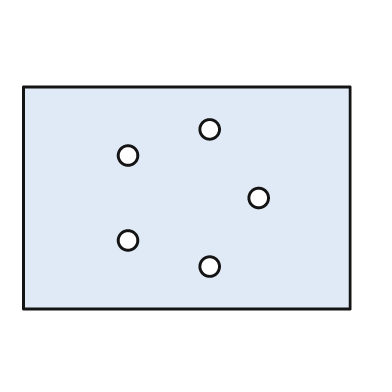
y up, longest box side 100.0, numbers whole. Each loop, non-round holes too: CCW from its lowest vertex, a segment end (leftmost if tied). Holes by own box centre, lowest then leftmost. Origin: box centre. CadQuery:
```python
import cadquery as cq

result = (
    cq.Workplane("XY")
    .moveTo(-50.0, -34.0)
    .lineTo(50.0, -34.0)
    .lineTo(50.0, 34.0)
    .lineTo(-50.0, 34.0)
    .close()
    .moveTo(7.0, -21.0)
    .circle(3.0)
    .moveTo(-18.0, -13.0)
    .circle(3.0)
    .moveTo(22.0, 0.0)
    .circle(3.0)
    .moveTo(-18.0, 13.0)
    .circle(3.0)
    .moveTo(7.0, 21.0)
    .circle(3.0)
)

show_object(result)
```